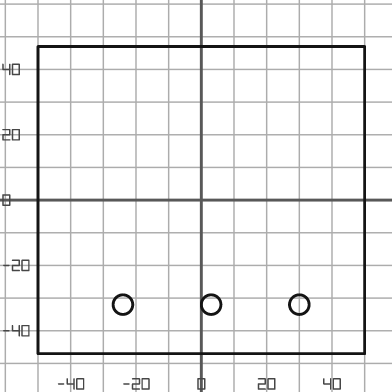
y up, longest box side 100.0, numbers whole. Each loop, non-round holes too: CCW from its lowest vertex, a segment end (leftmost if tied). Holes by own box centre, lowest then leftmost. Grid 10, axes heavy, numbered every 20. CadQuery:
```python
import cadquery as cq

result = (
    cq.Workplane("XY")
    .moveTo(-50.0, -47.0)
    .lineTo(50.0, -47.0)
    .lineTo(50.0, 47.0)
    .lineTo(-50.0, 47.0)
    .close()
    .moveTo(-24.0, -32.0)
    .circle(3.0)
    .moveTo(3.0, -32.0)
    .circle(3.0)
    .moveTo(30.0, -32.0)
    .circle(3.0)
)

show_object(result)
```